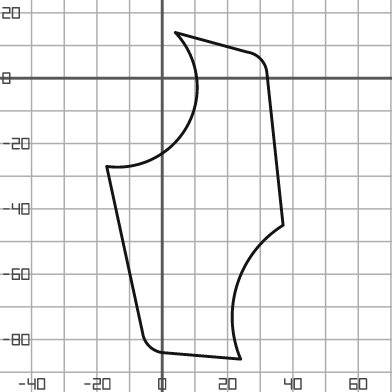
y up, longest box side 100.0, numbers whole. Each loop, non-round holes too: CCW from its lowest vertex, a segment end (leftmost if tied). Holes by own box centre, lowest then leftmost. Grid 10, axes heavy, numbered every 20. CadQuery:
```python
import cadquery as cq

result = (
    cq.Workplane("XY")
    .moveTo(24.0, -86.0)
    .threePointArc((23.0, -63.0), (37.0, -45.0))
    .lineTo(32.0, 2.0)
    .threePointArc((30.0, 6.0), (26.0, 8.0))
    .lineTo(4.0, 14.0)
    .threePointArc((8.0, -14.0), (-17.0, -27.0))
    .lineTo(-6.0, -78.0)
    .threePointArc((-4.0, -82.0), (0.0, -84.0))
    .close()
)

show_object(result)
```